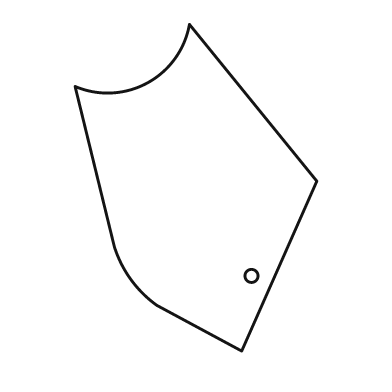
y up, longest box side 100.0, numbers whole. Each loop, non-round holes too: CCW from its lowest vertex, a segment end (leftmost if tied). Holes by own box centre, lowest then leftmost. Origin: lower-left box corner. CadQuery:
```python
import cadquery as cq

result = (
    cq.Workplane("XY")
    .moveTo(51.0, 0.0)
    .lineTo(74.0, 52.0)
    .lineTo(35.0, 100.0)
    .threePointArc((22.0, 82.0), (0.0, 81.0))
    .lineTo(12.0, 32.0)
    .threePointArc((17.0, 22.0), (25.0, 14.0))
    .close()
    .moveTo(54.0, 23.0)
    .circle(2.0)
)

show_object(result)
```